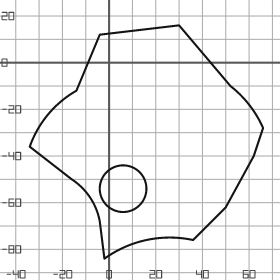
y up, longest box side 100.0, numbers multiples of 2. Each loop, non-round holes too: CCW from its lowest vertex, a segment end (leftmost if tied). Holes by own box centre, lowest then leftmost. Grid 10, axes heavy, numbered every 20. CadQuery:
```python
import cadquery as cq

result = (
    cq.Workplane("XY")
    .moveTo(-2.0, -84.0)
    .threePointArc((16.0, -76.0), (36.0, -76.0))
    .lineTo(50.0, -62.0)
    .lineTo(62.0, -40.0)
    .lineTo(66.0, -28.0)
    .threePointArc((60.0, -18.0), (52.0, -10.0))
    .lineTo(30.0, 16.0)
    .lineTo(-4.0, 12.0)
    .lineTo(-14.0, -12.0)
    .threePointArc((-26.0, -22.0), (-34.0, -36.0))
    .lineTo(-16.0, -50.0)
    .threePointArc((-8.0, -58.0), (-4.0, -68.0))
    .close()
    .moveTo(6.0, -54.0)
    .circle(10.0)
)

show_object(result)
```